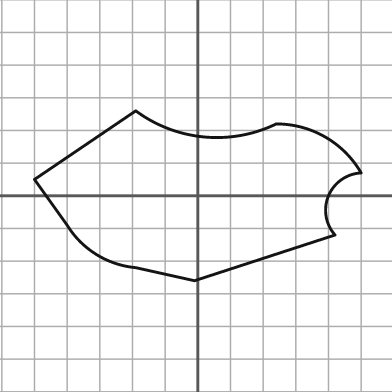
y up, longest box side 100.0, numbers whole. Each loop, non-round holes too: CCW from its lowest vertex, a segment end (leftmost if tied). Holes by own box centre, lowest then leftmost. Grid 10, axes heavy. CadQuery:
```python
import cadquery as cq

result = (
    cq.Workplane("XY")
    .moveTo(-1.0, -26.0)
    .lineTo(42.0, -12.0)
    .threePointArc((40.0, 0.0), (50.0, 7.0))
    .threePointArc((39.0, 18.0), (24.0, 22.0))
    .threePointArc((2.0, 18.0), (-19.0, 26.0))
    .lineTo(-50.0, 5.0)
    .lineTo(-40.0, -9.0)
    .threePointArc((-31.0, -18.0), (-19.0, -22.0))
    .close()
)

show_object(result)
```